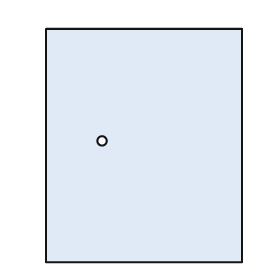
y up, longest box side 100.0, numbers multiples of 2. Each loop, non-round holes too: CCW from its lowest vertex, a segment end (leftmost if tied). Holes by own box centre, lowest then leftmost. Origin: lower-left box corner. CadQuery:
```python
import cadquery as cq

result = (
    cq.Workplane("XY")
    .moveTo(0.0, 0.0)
    .lineTo(84.0, 0.0)
    .lineTo(84.0, 100.0)
    .lineTo(0.0, 100.0)
    .close()
    .moveTo(24.0, 52.0)
    .circle(2.0)
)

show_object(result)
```